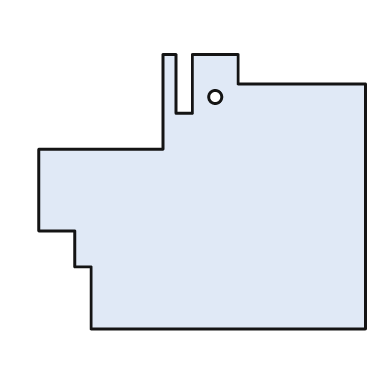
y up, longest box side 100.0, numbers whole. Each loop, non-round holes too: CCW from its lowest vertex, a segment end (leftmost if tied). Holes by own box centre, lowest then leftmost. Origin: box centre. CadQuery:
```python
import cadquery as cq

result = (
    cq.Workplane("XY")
    .moveTo(-34.0, -42.0)
    .lineTo(50.0, -42.0)
    .lineTo(50.0, 33.0)
    .lineTo(11.0, 33.0)
    .lineTo(11.0, 42.0)
    .lineTo(-3.0, 42.0)
    .lineTo(-3.0, 24.0)
    .lineTo(-8.0, 24.0)
    .lineTo(-8.0, 42.0)
    .lineTo(-12.0, 42.0)
    .lineTo(-12.0, 13.0)
    .lineTo(-50.0, 13.0)
    .lineTo(-50.0, -12.0)
    .lineTo(-39.0, -12.0)
    .lineTo(-39.0, -23.0)
    .lineTo(-34.0, -23.0)
    .close()
    .moveTo(4.0, 29.0)
    .circle(2.0)
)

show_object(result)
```